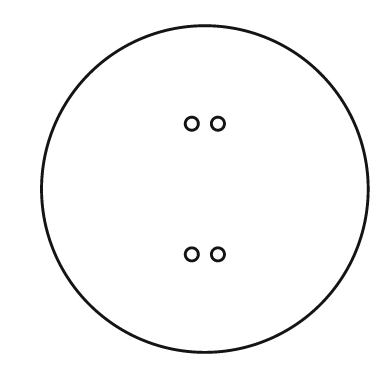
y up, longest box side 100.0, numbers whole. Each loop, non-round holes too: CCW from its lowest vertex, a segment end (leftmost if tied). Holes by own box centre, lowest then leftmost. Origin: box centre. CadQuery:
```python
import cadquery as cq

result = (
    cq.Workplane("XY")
    .moveTo(0.0, 0.0)
    .circle(50.0)
    .moveTo(-4.0, -20.0)
    .circle(2.0)
    .moveTo(4.0, -20.0)
    .circle(2.0)
    .moveTo(-4.0, 20.0)
    .circle(2.0)
    .moveTo(4.0, 20.0)
    .circle(2.0)
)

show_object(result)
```